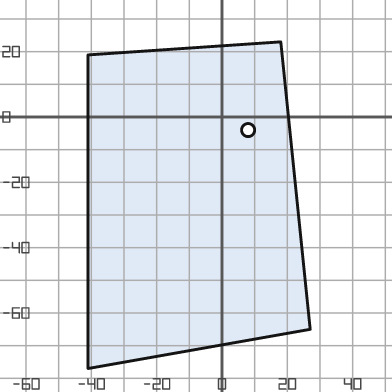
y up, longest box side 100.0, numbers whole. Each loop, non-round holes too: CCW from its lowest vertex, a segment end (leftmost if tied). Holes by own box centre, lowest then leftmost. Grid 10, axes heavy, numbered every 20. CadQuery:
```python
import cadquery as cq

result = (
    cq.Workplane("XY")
    .moveTo(-41.0, -77.0)
    .lineTo(27.0, -65.0)
    .lineTo(18.0, 23.0)
    .lineTo(-41.0, 19.0)
    .close()
    .moveTo(8.0, -4.0)
    .circle(2.0)
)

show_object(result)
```